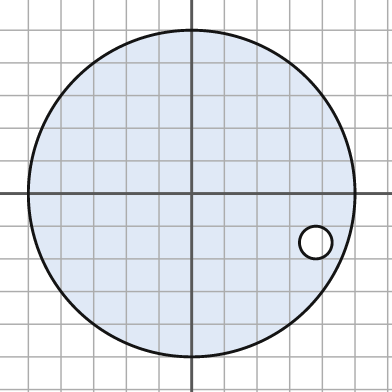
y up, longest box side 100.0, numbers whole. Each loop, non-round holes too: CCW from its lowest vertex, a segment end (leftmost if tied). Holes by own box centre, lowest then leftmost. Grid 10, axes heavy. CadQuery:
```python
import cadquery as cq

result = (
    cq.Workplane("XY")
    .moveTo(0.0, 0.0)
    .circle(50.0)
    .moveTo(38.0, -15.0)
    .circle(5.0)
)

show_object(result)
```